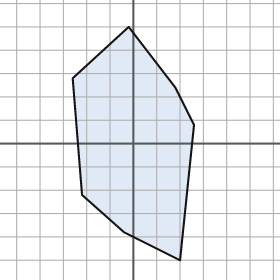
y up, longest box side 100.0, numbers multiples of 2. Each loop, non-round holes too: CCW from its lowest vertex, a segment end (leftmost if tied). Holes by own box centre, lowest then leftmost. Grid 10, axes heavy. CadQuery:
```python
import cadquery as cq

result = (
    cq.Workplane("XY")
    .moveTo(20.0, -50.0)
    .lineTo(26.0, 8.0)
    .lineTo(18.0, 24.0)
    .lineTo(-2.0, 50.0)
    .lineTo(-26.0, 28.0)
    .lineTo(-22.0, -22.0)
    .lineTo(-4.0, -38.0)
    .close()
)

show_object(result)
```